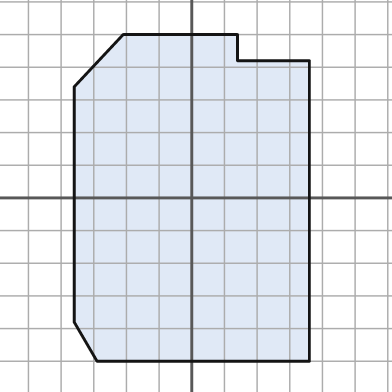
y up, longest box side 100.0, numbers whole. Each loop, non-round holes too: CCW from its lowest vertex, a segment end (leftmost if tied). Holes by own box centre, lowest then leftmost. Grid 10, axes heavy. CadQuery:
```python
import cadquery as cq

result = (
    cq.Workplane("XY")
    .moveTo(-29.0, -50.0)
    .lineTo(36.0, -50.0)
    .lineTo(36.0, 42.0)
    .lineTo(14.0, 42.0)
    .lineTo(14.0, 50.0)
    .lineTo(-21.0, 50.0)
    .lineTo(-36.0, 34.0)
    .lineTo(-36.0, -38.0)
    .close()
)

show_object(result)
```